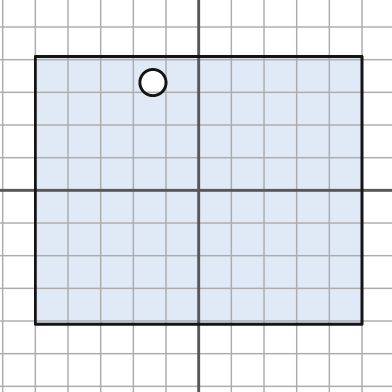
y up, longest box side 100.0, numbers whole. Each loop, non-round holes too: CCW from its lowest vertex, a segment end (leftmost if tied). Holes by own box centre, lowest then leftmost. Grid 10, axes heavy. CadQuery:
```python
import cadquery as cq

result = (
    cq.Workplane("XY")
    .moveTo(-50.0, -41.0)
    .lineTo(50.0, -41.0)
    .lineTo(50.0, 41.0)
    .lineTo(-50.0, 41.0)
    .close()
    .moveTo(-14.0, 33.0)
    .circle(4.0)
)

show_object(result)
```